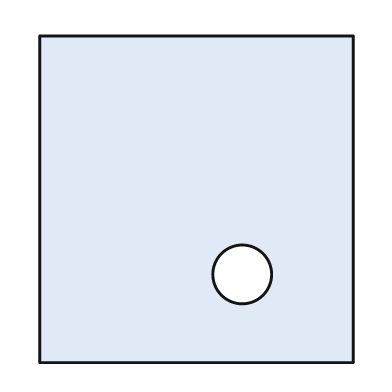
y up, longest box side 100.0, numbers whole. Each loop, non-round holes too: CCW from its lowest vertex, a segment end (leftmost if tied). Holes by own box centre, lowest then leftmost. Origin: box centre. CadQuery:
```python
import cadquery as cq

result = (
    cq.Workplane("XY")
    .moveTo(-48.0, -50.0)
    .lineTo(48.0, -50.0)
    .lineTo(48.0, 50.0)
    .lineTo(-48.0, 50.0)
    .close()
    .moveTo(14.0, -23.0)
    .circle(9.0)
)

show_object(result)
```